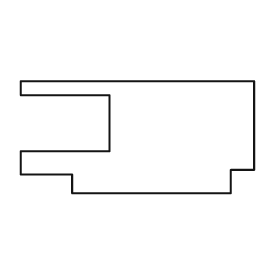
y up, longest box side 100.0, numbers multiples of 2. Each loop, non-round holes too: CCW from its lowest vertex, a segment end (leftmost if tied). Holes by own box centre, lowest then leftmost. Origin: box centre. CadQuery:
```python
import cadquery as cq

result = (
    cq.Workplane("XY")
    .moveTo(-28.0, -24.0)
    .lineTo(40.0, -24.0)
    .lineTo(40.0, -14.0)
    .lineTo(50.0, -14.0)
    .lineTo(50.0, 24.0)
    .lineTo(-50.0, 24.0)
    .lineTo(-50.0, 18.0)
    .lineTo(-12.0, 18.0)
    .lineTo(-12.0, -6.0)
    .lineTo(-50.0, -6.0)
    .lineTo(-50.0, -16.0)
    .lineTo(-28.0, -16.0)
    .close()
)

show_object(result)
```